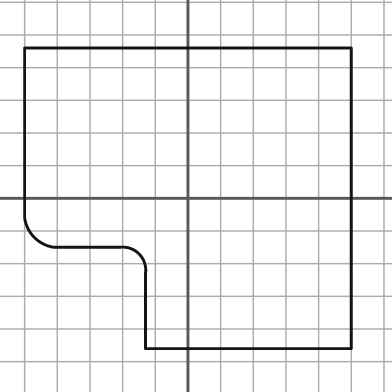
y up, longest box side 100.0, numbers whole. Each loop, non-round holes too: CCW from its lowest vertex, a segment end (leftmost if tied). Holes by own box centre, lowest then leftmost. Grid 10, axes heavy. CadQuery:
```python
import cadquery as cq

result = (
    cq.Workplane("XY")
    .moveTo(-13.0, -46.0)
    .lineTo(50.0, -46.0)
    .lineTo(50.0, 46.0)
    .lineTo(-50.0, 46.0)
    .lineTo(-50.0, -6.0)
    .threePointArc((-47.0, -12.0), (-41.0, -15.0))
    .lineTo(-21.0, -15.0)
    .threePointArc((-15.0, -17.0), (-13.0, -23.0))
    .close()
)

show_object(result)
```